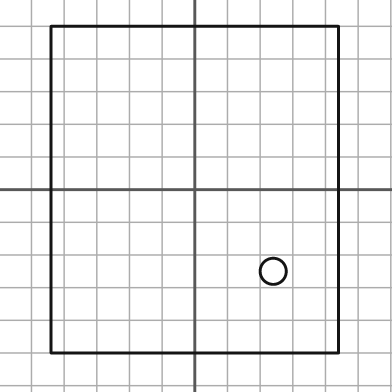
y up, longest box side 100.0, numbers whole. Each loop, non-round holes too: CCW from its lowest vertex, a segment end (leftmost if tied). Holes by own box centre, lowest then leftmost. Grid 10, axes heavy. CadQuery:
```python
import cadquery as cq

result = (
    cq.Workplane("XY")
    .moveTo(-44.0, -50.0)
    .lineTo(44.0, -50.0)
    .lineTo(44.0, 50.0)
    .lineTo(-44.0, 50.0)
    .close()
    .moveTo(24.0, -25.0)
    .circle(4.0)
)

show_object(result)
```